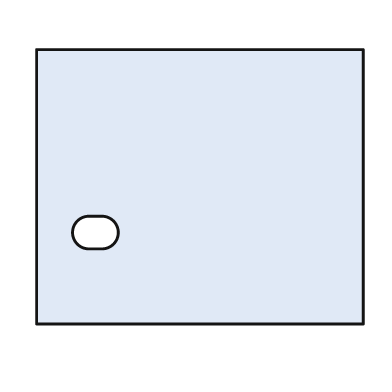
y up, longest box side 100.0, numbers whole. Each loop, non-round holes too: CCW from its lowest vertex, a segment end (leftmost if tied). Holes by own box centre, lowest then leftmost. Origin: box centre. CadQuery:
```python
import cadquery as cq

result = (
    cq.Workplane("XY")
    .moveTo(-50.0, -42.0)
    .lineTo(50.0, -42.0)
    .lineTo(50.0, 42.0)
    .lineTo(-50.0, 42.0)
    .close()
    .moveTo(-34.0, -19.0)
    .lineTo(-30.0, -19.0)
    .threePointArc((-25.0, -14.0), (-30.0, -9.0))
    .lineTo(-34.0, -9.0)
    .threePointArc((-39.0, -14.0), (-34.0, -19.0))
    .close()
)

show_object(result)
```